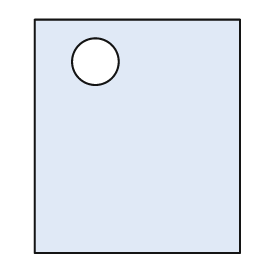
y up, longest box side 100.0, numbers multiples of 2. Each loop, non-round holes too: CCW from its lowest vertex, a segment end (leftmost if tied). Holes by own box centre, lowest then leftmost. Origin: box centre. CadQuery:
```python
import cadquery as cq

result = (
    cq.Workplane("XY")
    .moveTo(-44.0, -50.0)
    .lineTo(44.0, -50.0)
    .lineTo(44.0, 50.0)
    .lineTo(-44.0, 50.0)
    .close()
    .moveTo(-18.0, 32.0)
    .circle(10.0)
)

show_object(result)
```